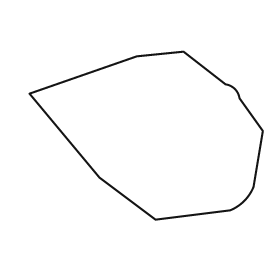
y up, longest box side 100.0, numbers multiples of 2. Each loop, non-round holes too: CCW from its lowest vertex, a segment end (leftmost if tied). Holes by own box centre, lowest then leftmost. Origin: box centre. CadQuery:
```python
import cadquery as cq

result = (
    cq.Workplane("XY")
    .moveTo(4.0, -36.0)
    .lineTo(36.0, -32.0)
    .threePointArc((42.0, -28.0), (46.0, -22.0))
    .lineTo(50.0, 2.0)
    .lineTo(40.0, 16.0)
    .threePointArc((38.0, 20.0), (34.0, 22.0))
    .lineTo(16.0, 36.0)
    .lineTo(-4.0, 34.0)
    .lineTo(-50.0, 18.0)
    .lineTo(-20.0, -18.0)
    .close()
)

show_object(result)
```